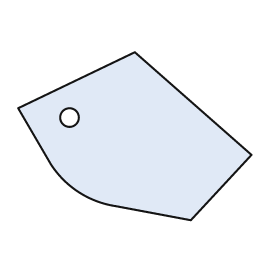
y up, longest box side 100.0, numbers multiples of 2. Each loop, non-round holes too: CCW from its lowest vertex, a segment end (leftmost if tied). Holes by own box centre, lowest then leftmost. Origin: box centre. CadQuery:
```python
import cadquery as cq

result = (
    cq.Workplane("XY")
    .moveTo(24.0, -36.0)
    .lineTo(50.0, -8.0)
    .lineTo(0.0, 36.0)
    .lineTo(-50.0, 12.0)
    .lineTo(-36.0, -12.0)
    .threePointArc((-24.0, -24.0), (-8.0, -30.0))
    .close()
    .moveTo(-28.0, 8.0)
    .circle(4.0)
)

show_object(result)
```